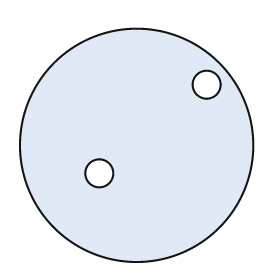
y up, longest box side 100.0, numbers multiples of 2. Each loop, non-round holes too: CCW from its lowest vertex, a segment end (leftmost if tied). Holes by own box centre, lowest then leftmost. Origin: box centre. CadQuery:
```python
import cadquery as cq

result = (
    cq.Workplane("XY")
    .moveTo(0.0, 0.0)
    .circle(50.0)
    .moveTo(-16.0, -12.0)
    .circle(6.0)
    .moveTo(30.0, 26.0)
    .circle(6.0)
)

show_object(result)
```